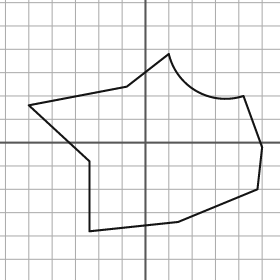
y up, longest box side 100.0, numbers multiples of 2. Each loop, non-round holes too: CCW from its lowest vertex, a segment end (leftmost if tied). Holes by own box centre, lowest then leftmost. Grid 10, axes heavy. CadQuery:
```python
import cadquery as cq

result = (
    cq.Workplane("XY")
    .moveTo(-24.0, -38.0)
    .lineTo(14.0, -34.0)
    .lineTo(48.0, -20.0)
    .lineTo(50.0, -2.0)
    .lineTo(42.0, 20.0)
    .threePointArc((22.0, 22.0), (10.0, 38.0))
    .lineTo(-8.0, 24.0)
    .lineTo(-50.0, 16.0)
    .lineTo(-24.0, -8.0)
    .close()
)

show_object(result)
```